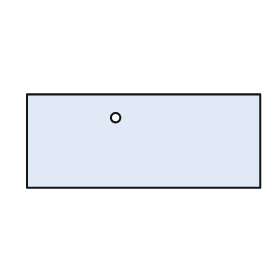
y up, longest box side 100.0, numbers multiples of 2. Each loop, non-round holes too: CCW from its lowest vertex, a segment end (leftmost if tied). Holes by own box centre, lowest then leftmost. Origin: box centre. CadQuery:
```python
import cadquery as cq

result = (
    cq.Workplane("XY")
    .moveTo(-50.0, -20.0)
    .lineTo(50.0, -20.0)
    .lineTo(50.0, 20.0)
    .lineTo(-50.0, 20.0)
    .close()
    .moveTo(-12.0, 10.0)
    .circle(2.0)
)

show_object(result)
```